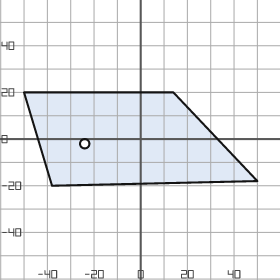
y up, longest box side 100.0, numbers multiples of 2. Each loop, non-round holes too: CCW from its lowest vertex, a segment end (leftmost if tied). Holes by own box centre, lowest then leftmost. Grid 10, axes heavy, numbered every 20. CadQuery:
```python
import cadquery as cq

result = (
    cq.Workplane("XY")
    .moveTo(-38.0, -20.0)
    .lineTo(50.0, -18.0)
    .lineTo(14.0, 20.0)
    .lineTo(-50.0, 20.0)
    .close()
    .moveTo(-24.0, -2.0)
    .circle(2.0)
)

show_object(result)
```